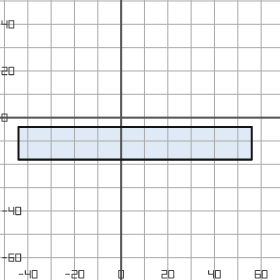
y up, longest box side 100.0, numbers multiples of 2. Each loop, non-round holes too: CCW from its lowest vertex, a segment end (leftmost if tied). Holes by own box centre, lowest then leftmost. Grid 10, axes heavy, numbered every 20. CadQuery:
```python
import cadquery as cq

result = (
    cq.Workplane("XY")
    .moveTo(-44.0, -18.0)
    .lineTo(56.0, -18.0)
    .lineTo(56.0, -4.0)
    .lineTo(-44.0, -4.0)
    .close()
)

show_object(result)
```